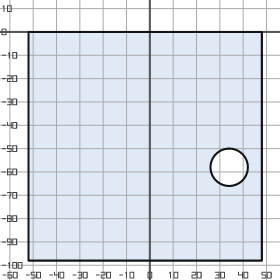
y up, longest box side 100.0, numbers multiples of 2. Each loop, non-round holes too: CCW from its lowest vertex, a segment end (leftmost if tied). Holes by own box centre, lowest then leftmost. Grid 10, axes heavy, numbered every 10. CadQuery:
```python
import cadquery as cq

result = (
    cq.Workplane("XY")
    .moveTo(-52.0, -98.0)
    .lineTo(48.0, -98.0)
    .lineTo(48.0, 0.0)
    .lineTo(-52.0, 0.0)
    .close()
    .moveTo(34.0, -58.0)
    .circle(8.0)
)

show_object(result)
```